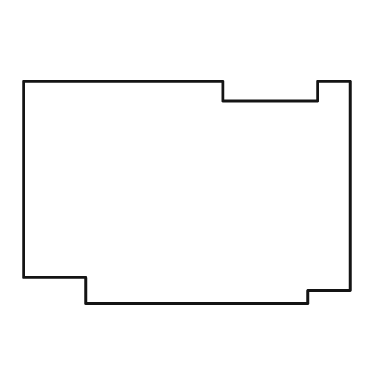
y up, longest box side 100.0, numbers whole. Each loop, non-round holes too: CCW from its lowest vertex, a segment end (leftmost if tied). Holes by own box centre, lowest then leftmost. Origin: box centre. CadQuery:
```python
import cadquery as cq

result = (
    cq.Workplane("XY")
    .moveTo(-31.0, -34.0)
    .lineTo(37.0, -34.0)
    .lineTo(37.0, -30.0)
    .lineTo(50.0, -30.0)
    .lineTo(50.0, 34.0)
    .lineTo(40.0, 34.0)
    .lineTo(40.0, 28.0)
    .lineTo(11.0, 28.0)
    .lineTo(11.0, 34.0)
    .lineTo(-50.0, 34.0)
    .lineTo(-50.0, -26.0)
    .lineTo(-31.0, -26.0)
    .close()
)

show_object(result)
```